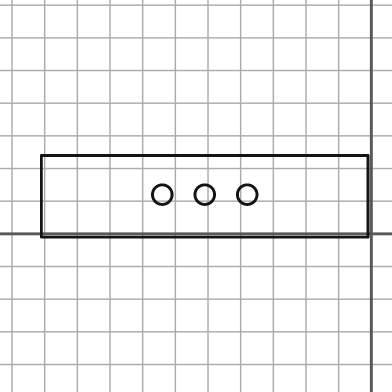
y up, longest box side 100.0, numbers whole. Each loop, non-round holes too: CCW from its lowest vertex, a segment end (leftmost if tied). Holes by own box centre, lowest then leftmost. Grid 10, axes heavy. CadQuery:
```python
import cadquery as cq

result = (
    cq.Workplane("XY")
    .moveTo(-101.0, -1.0)
    .lineTo(-1.0, -1.0)
    .lineTo(-1.0, 24.0)
    .lineTo(-101.0, 24.0)
    .close()
    .moveTo(-64.0, 12.0)
    .circle(3.0)
    .moveTo(-51.0, 12.0)
    .circle(3.0)
    .moveTo(-38.0, 12.0)
    .circle(3.0)
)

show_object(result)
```